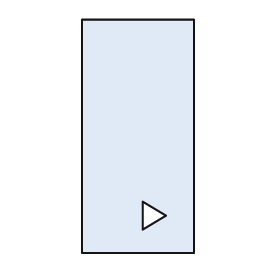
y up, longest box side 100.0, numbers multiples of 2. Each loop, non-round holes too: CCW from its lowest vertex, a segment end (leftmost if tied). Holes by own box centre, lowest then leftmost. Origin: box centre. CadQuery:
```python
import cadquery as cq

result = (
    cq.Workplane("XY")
    .moveTo(-24.0, -50.0)
    .lineTo(24.0, -50.0)
    .lineTo(24.0, 50.0)
    .lineTo(-24.0, 50.0)
    .close()
    .moveTo(2.0, -40.0)
    .lineTo(12.0, -34.0)
    .lineTo(2.0, -28.0)
    .close()
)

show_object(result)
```